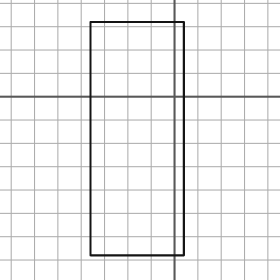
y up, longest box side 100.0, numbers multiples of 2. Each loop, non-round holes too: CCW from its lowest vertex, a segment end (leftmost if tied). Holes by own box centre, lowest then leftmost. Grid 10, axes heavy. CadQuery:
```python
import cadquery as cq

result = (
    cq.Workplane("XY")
    .moveTo(-36.0, -68.0)
    .lineTo(4.0, -68.0)
    .lineTo(4.0, 32.0)
    .lineTo(-36.0, 32.0)
    .close()
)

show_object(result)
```